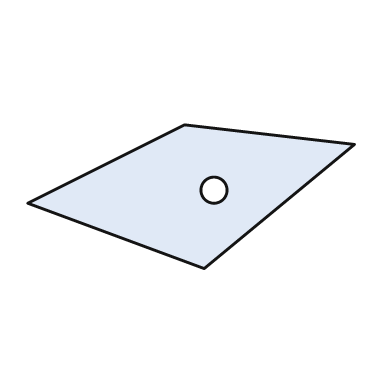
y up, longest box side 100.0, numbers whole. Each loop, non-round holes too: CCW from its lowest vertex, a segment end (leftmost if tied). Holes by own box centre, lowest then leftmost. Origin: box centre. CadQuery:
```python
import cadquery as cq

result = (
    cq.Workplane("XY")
    .moveTo(4.0, -22.0)
    .lineTo(50.0, 16.0)
    .lineTo(-2.0, 22.0)
    .lineTo(-50.0, -2.0)
    .close()
    .moveTo(7.0, 2.0)
    .circle(4.0)
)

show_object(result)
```